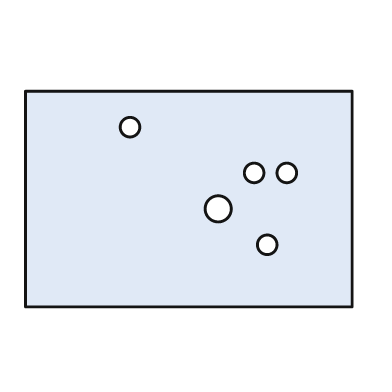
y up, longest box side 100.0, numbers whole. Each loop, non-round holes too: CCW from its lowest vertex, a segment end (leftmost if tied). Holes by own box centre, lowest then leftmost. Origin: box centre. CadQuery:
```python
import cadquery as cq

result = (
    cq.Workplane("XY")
    .moveTo(-50.0, -33.0)
    .lineTo(50.0, -33.0)
    .lineTo(50.0, 33.0)
    .lineTo(-50.0, 33.0)
    .close()
    .moveTo(24.0, -14.0)
    .circle(3.0)
    .moveTo(9.0, -3.0)
    .circle(4.0)
    .moveTo(20.0, 8.0)
    .circle(3.0)
    .moveTo(30.0, 8.0)
    .circle(3.0)
    .moveTo(-18.0, 22.0)
    .circle(3.0)
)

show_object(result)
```